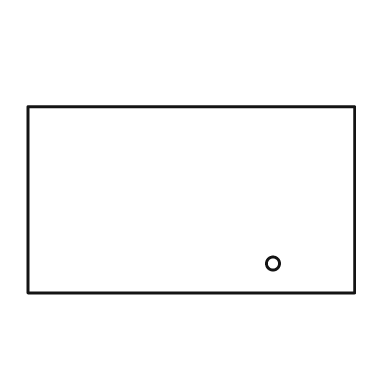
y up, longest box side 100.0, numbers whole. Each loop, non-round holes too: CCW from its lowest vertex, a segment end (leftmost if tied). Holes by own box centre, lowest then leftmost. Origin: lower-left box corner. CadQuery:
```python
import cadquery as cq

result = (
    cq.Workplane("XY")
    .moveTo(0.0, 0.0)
    .lineTo(100.0, 0.0)
    .lineTo(100.0, 57.0)
    .lineTo(0.0, 57.0)
    .close()
    .moveTo(75.0, 9.0)
    .circle(2.0)
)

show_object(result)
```